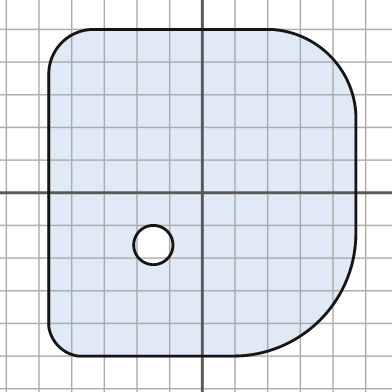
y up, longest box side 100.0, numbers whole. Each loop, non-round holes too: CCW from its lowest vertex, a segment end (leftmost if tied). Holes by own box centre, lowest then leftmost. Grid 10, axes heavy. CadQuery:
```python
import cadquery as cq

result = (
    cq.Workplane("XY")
    .moveTo(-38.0, -50.0)
    .lineTo(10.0, -50.0)
    .threePointArc((36.0, -39.0), (47.0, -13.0))
    .lineTo(47.0, 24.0)
    .threePointArc((39.0, 42.0), (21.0, 50.0))
    .lineTo(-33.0, 50.0)
    .threePointArc((-43.0, 46.0), (-47.0, 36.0))
    .lineTo(-47.0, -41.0)
    .threePointArc((-44.0, -47.0), (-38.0, -50.0))
    .close()
    .moveTo(-15.0, -16.0)
    .circle(6.0)
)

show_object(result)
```